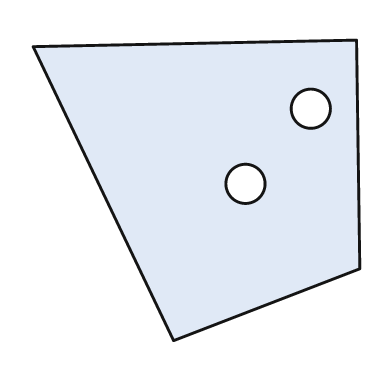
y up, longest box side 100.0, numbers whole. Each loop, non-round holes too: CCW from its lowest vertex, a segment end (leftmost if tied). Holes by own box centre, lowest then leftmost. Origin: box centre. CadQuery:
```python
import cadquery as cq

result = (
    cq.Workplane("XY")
    .moveTo(-7.0, -46.0)
    .lineTo(50.0, -24.0)
    .lineTo(49.0, 46.0)
    .lineTo(-50.0, 44.0)
    .close()
    .moveTo(15.0, 2.0)
    .circle(6.0)
    .moveTo(35.0, 25.0)
    .circle(6.0)
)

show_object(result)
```